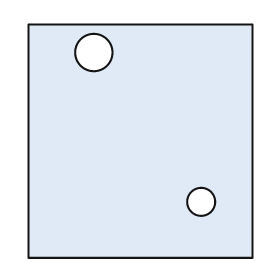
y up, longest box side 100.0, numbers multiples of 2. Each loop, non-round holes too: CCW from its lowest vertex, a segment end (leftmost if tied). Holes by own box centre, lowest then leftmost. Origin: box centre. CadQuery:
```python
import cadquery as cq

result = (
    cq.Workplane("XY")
    .moveTo(-48.0, -50.0)
    .lineTo(48.0, -50.0)
    .lineTo(48.0, 50.0)
    .lineTo(-48.0, 50.0)
    .close()
    .moveTo(26.0, -26.0)
    .circle(6.0)
    .moveTo(-20.0, 38.0)
    .circle(8.0)
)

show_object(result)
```